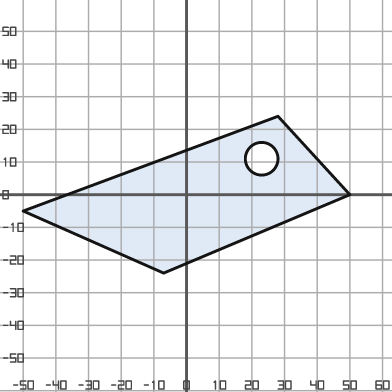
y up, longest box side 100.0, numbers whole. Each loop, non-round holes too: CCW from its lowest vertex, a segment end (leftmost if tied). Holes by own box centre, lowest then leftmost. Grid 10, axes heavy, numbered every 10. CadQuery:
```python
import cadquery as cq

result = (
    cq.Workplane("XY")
    .moveTo(-7.0, -24.0)
    .lineTo(50.0, 0.0)
    .lineTo(28.0, 24.0)
    .lineTo(-50.0, -5.0)
    .close()
    .moveTo(23.0, 11.0)
    .circle(5.0)
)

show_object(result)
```